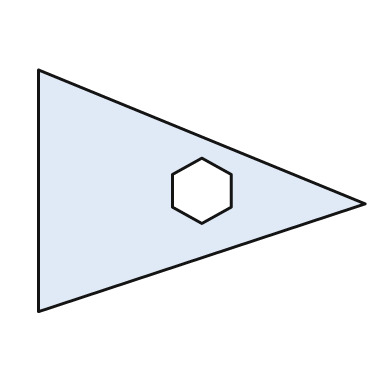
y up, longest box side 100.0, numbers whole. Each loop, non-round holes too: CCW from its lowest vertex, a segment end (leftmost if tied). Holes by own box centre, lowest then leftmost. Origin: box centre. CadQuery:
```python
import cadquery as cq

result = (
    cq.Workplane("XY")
    .moveTo(-50.0, -37.0)
    .lineTo(50.0, -4.0)
    .lineTo(-50.0, 37.0)
    .close()
    .moveTo(0.0, -10.0)
    .lineTo(9.0, -5.0)
    .lineTo(9.0, 5.0)
    .lineTo(0.0, 10.0)
    .lineTo(-9.0, 5.0)
    .lineTo(-9.0, -5.0)
    .close()
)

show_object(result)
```